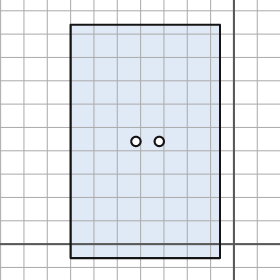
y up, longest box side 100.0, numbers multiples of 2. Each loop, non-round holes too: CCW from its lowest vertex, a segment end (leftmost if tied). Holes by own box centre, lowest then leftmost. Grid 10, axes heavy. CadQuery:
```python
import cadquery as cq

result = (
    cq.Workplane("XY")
    .moveTo(-70.0, -6.0)
    .lineTo(-6.0, -6.0)
    .lineTo(-6.0, 94.0)
    .lineTo(-70.0, 94.0)
    .close()
    .moveTo(-42.0, 44.0)
    .circle(2.0)
    .moveTo(-32.0, 44.0)
    .circle(2.0)
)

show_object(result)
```